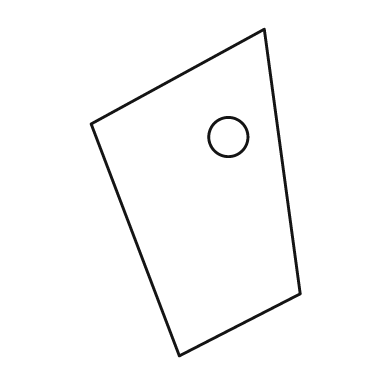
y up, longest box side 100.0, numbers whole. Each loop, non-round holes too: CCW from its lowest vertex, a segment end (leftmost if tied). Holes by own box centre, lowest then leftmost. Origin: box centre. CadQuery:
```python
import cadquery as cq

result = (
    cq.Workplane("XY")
    .moveTo(-5.0, -50.0)
    .lineTo(32.0, -31.0)
    .lineTo(21.0, 50.0)
    .lineTo(-32.0, 21.0)
    .close()
    .moveTo(10.0, 17.0)
    .circle(6.0)
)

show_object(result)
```